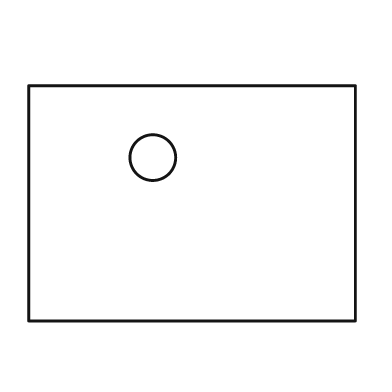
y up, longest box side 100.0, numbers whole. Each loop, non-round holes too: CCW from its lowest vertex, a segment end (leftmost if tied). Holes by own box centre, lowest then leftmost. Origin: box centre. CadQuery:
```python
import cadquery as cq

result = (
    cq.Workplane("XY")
    .moveTo(-50.0, -36.0)
    .lineTo(50.0, -36.0)
    .lineTo(50.0, 36.0)
    .lineTo(-50.0, 36.0)
    .close()
    .moveTo(-12.0, 14.0)
    .circle(7.0)
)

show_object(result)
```